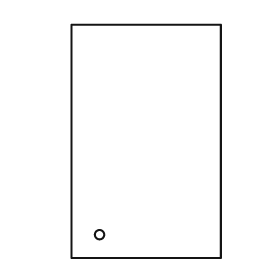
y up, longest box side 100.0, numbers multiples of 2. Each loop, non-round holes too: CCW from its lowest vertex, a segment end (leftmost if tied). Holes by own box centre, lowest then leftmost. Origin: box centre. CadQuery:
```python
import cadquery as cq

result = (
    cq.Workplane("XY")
    .moveTo(-32.0, -50.0)
    .lineTo(32.0, -50.0)
    .lineTo(32.0, 50.0)
    .lineTo(-32.0, 50.0)
    .close()
    .moveTo(-20.0, -40.0)
    .circle(2.0)
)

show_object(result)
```